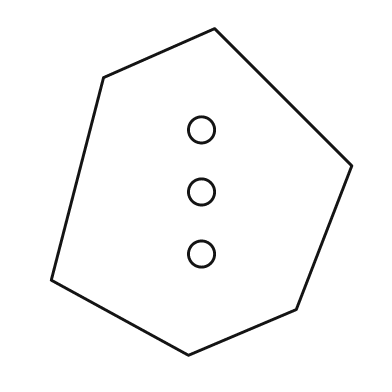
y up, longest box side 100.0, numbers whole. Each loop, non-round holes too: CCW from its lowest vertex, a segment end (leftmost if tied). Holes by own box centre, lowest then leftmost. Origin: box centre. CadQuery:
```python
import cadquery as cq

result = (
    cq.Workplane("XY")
    .moveTo(-4.0, -50.0)
    .lineTo(29.0, -36.0)
    .lineTo(46.0, 8.0)
    .lineTo(4.0, 50.0)
    .lineTo(-30.0, 35.0)
    .lineTo(-46.0, -27.0)
    .close()
    .moveTo(0.0, -19.0)
    .circle(4.0)
    .moveTo(0.0, 0.0)
    .circle(4.0)
    .moveTo(0.0, 19.0)
    .circle(4.0)
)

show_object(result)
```